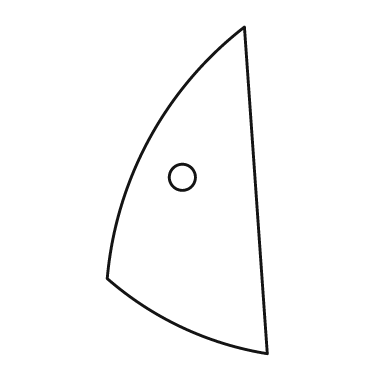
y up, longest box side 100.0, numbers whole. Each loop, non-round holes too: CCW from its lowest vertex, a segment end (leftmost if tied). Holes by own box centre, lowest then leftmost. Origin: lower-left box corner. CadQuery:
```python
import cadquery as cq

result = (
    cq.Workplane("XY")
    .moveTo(49.0, 0.0)
    .lineTo(42.0, 100.0)
    .threePointArc((13.0, 66.0), (0.0, 23.0))
    .threePointArc((23.0, 8.0), (49.0, 0.0))
    .close()
    .moveTo(23.0, 54.0)
    .circle(4.0)
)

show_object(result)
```